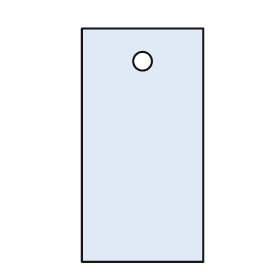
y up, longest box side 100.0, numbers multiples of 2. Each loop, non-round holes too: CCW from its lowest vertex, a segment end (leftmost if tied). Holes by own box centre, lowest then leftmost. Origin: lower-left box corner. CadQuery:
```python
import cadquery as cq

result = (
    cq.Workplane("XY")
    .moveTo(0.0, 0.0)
    .lineTo(52.0, 0.0)
    .lineTo(52.0, 100.0)
    .lineTo(0.0, 100.0)
    .close()
    .moveTo(26.0, 86.0)
    .circle(4.0)
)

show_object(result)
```